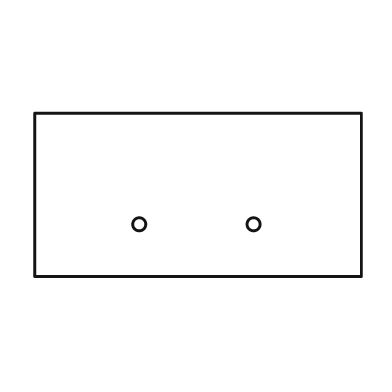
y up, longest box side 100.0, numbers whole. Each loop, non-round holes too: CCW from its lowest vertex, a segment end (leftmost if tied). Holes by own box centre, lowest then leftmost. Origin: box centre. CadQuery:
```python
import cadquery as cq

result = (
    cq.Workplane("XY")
    .moveTo(-50.0, -25.0)
    .lineTo(50.0, -25.0)
    .lineTo(50.0, 25.0)
    .lineTo(-50.0, 25.0)
    .close()
    .moveTo(-18.0, -9.0)
    .circle(2.0)
    .moveTo(17.0, -9.0)
    .circle(2.0)
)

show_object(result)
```